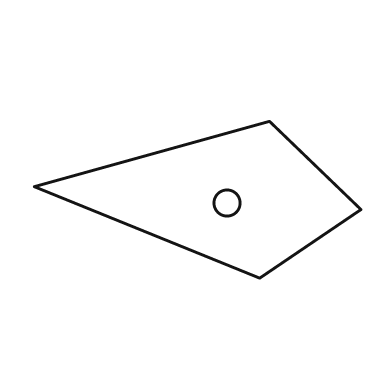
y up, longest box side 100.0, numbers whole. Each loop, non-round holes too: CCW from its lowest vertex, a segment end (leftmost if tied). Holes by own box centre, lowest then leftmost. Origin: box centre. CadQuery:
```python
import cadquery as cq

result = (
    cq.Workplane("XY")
    .moveTo(19.0, -24.0)
    .lineTo(50.0, -3.0)
    .lineTo(22.0, 24.0)
    .lineTo(-50.0, 4.0)
    .close()
    .moveTo(9.0, -1.0)
    .circle(4.0)
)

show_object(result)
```